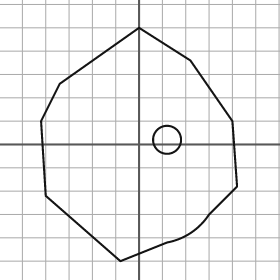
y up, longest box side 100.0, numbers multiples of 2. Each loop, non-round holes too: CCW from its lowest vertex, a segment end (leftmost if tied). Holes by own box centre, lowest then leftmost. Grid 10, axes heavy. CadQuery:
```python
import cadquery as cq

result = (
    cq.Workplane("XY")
    .moveTo(-8.0, -50.0)
    .lineTo(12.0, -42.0)
    .threePointArc((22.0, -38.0), (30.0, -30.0))
    .lineTo(42.0, -18.0)
    .lineTo(40.0, 10.0)
    .lineTo(22.0, 36.0)
    .lineTo(0.0, 50.0)
    .lineTo(-34.0, 26.0)
    .lineTo(-42.0, 10.0)
    .lineTo(-40.0, -22.0)
    .close()
    .moveTo(12.0, 2.0)
    .circle(6.0)
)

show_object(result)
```